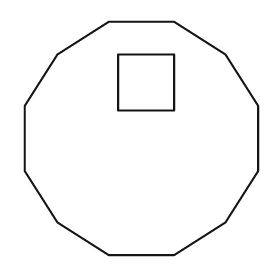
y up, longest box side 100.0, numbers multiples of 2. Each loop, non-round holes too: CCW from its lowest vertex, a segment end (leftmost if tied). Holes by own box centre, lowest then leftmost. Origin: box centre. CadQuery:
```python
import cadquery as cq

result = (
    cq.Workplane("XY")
    .moveTo(-14.0, -50.0)
    .lineTo(14.0, -50.0)
    .lineTo(36.0, -36.0)
    .lineTo(50.0, -14.0)
    .lineTo(50.0, 14.0)
    .lineTo(36.0, 36.0)
    .lineTo(14.0, 50.0)
    .lineTo(-14.0, 50.0)
    .lineTo(-36.0, 36.0)
    .lineTo(-50.0, 14.0)
    .lineTo(-50.0, -14.0)
    .lineTo(-36.0, -36.0)
    .close()
    .moveTo(-10.0, 12.0)
    .lineTo(14.0, 12.0)
    .lineTo(14.0, 36.0)
    .lineTo(-10.0, 36.0)
    .close()
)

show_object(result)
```